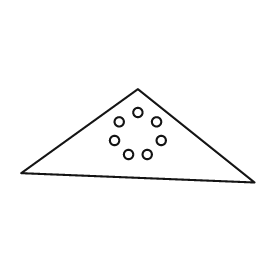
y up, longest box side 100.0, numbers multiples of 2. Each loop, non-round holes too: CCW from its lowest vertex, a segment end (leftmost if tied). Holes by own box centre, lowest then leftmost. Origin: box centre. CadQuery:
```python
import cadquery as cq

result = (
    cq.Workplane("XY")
    .moveTo(50.0, -20.0)
    .lineTo(0.0, 20.0)
    .lineTo(-50.0, -16.0)
    .close()
    .moveTo(-4.0, -8.0)
    .circle(2.0)
    .moveTo(4.0, -8.0)
    .circle(2.0)
    .moveTo(-10.0, -2.0)
    .circle(2.0)
    .moveTo(10.0, -2.0)
    .circle(2.0)
    .moveTo(-8.0, 6.0)
    .circle(2.0)
    .moveTo(8.0, 6.0)
    .circle(2.0)
    .moveTo(0.0, 10.0)
    .circle(2.0)
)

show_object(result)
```